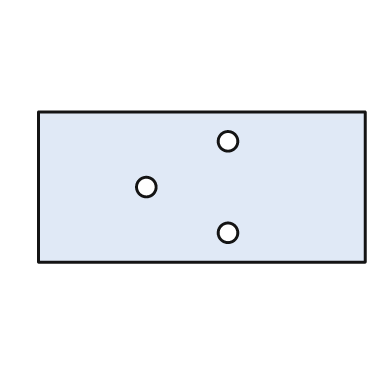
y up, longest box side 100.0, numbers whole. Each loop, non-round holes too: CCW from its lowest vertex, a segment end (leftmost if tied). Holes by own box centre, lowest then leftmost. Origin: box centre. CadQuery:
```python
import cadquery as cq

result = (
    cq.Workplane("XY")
    .moveTo(-50.0, -23.0)
    .lineTo(50.0, -23.0)
    .lineTo(50.0, 23.0)
    .lineTo(-50.0, 23.0)
    .close()
    .moveTo(8.0, -14.0)
    .circle(3.0)
    .moveTo(-17.0, 0.0)
    .circle(3.0)
    .moveTo(8.0, 14.0)
    .circle(3.0)
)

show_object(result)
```